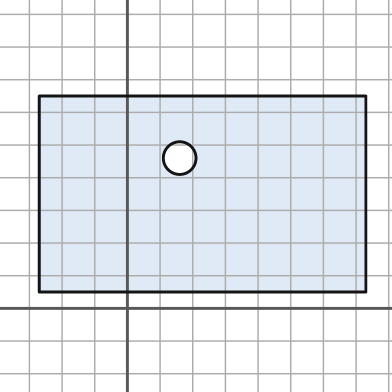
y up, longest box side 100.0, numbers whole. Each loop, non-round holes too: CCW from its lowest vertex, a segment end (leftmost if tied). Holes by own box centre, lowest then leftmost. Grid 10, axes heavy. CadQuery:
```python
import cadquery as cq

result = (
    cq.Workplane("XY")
    .moveTo(-27.0, 5.0)
    .lineTo(73.0, 5.0)
    .lineTo(73.0, 65.0)
    .lineTo(-27.0, 65.0)
    .close()
    .moveTo(16.0, 46.0)
    .circle(5.0)
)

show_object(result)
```